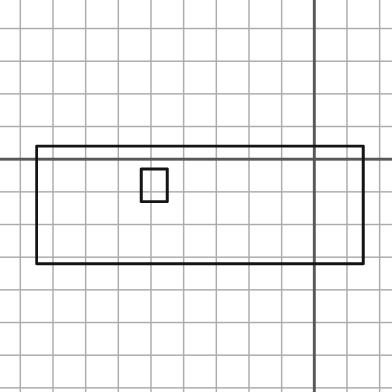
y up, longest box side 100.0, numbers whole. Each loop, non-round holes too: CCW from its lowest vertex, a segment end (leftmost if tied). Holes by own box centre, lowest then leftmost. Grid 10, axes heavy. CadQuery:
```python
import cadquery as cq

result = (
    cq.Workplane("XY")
    .moveTo(-85.0, -32.0)
    .lineTo(15.0, -32.0)
    .lineTo(15.0, 4.0)
    .lineTo(-85.0, 4.0)
    .close()
    .moveTo(-53.0, -13.0)
    .lineTo(-45.0, -13.0)
    .lineTo(-45.0, -3.0)
    .lineTo(-53.0, -3.0)
    .close()
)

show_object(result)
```